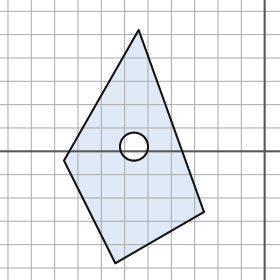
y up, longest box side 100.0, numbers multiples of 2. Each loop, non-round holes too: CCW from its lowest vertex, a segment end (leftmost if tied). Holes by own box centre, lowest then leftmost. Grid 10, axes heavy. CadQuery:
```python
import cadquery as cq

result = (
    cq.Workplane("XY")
    .moveTo(-64.0, -48.0)
    .lineTo(-26.0, -26.0)
    .lineTo(-54.0, 52.0)
    .lineTo(-86.0, -4.0)
    .close()
    .moveTo(-56.0, 2.0)
    .circle(6.0)
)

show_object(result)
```